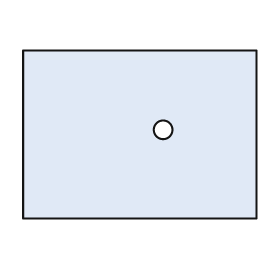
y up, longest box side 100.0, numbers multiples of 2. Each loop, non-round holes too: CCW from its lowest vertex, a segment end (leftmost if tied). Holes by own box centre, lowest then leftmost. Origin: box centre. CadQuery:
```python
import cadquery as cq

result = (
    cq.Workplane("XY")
    .moveTo(-50.0, -36.0)
    .lineTo(50.0, -36.0)
    .lineTo(50.0, 36.0)
    .lineTo(-50.0, 36.0)
    .close()
    .moveTo(10.0, 2.0)
    .circle(4.0)
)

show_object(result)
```